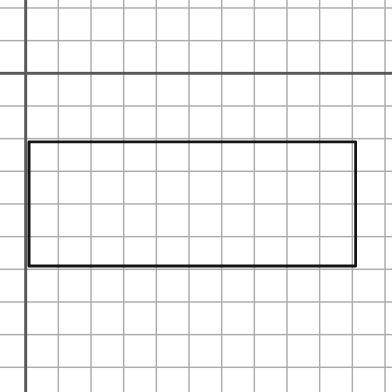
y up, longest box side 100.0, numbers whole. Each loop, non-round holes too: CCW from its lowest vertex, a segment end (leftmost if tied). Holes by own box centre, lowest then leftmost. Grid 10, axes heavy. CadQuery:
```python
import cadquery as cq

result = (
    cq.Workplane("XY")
    .moveTo(1.0, -59.0)
    .lineTo(101.0, -59.0)
    .lineTo(101.0, -21.0)
    .lineTo(1.0, -21.0)
    .close()
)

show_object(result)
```